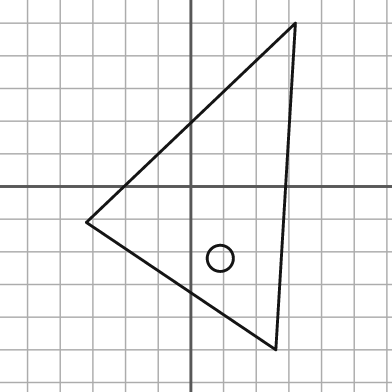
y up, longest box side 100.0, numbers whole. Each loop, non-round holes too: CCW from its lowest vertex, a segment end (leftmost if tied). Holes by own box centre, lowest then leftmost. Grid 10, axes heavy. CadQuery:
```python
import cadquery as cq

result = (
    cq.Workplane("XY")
    .moveTo(26.0, -50.0)
    .lineTo(32.0, 50.0)
    .lineTo(-32.0, -11.0)
    .close()
    .moveTo(9.0, -22.0)
    .circle(4.0)
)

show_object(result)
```